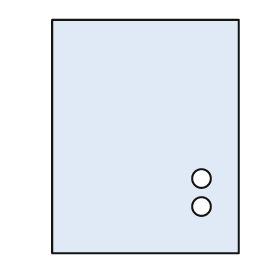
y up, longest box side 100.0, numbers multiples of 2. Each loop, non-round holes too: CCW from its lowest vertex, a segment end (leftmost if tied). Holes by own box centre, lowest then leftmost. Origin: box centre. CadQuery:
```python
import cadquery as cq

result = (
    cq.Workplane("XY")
    .moveTo(-40.0, -50.0)
    .lineTo(40.0, -50.0)
    .lineTo(40.0, 50.0)
    .lineTo(-40.0, 50.0)
    .close()
    .moveTo(24.0, -30.0)
    .circle(4.0)
    .moveTo(24.0, -18.0)
    .circle(4.0)
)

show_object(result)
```